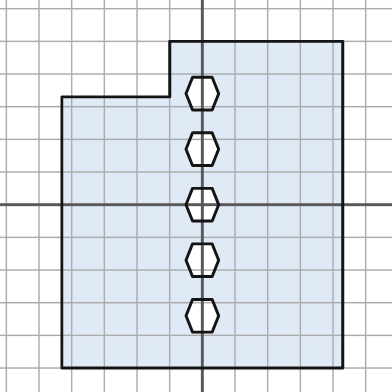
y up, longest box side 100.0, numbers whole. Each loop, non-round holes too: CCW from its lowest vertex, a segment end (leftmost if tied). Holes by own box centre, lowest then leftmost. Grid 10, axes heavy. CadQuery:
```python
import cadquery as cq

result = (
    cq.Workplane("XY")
    .moveTo(-43.0, -50.0)
    .lineTo(43.0, -50.0)
    .lineTo(43.0, 50.0)
    .lineTo(-10.0, 50.0)
    .lineTo(-10.0, 33.0)
    .lineTo(-43.0, 33.0)
    .close()
    .moveTo(-3.0, -39.0)
    .lineTo(3.0, -39.0)
    .lineTo(5.0, -34.0)
    .lineTo(3.0, -29.0)
    .lineTo(-3.0, -29.0)
    .lineTo(-5.0, -34.0)
    .close()
    .moveTo(-3.0, -22.0)
    .lineTo(3.0, -22.0)
    .lineTo(5.0, -17.0)
    .lineTo(3.0, -12.0)
    .lineTo(-3.0, -12.0)
    .lineTo(-5.0, -17.0)
    .close()
    .moveTo(-3.0, -5.0)
    .lineTo(3.0, -5.0)
    .lineTo(5.0, 0.0)
    .lineTo(3.0, 5.0)
    .lineTo(-3.0, 5.0)
    .lineTo(-5.0, 0.0)
    .close()
    .moveTo(-3.0, 12.0)
    .lineTo(3.0, 12.0)
    .lineTo(5.0, 17.0)
    .lineTo(3.0, 22.0)
    .lineTo(-3.0, 22.0)
    .lineTo(-5.0, 17.0)
    .close()
    .moveTo(-3.0, 29.0)
    .lineTo(3.0, 29.0)
    .lineTo(5.0, 34.0)
    .lineTo(3.0, 39.0)
    .lineTo(-3.0, 39.0)
    .lineTo(-5.0, 34.0)
    .close()
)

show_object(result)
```